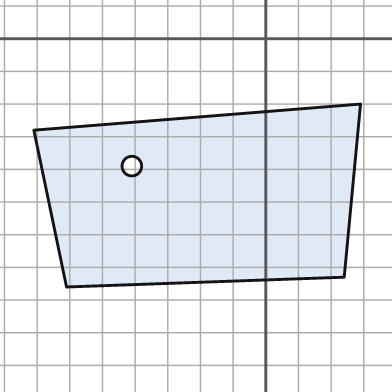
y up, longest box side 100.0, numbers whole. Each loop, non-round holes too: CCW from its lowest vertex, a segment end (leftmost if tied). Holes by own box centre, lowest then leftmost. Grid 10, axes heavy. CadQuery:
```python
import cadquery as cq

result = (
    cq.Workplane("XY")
    .moveTo(-61.0, -76.0)
    .lineTo(24.0, -73.0)
    .lineTo(29.0, -20.0)
    .lineTo(-71.0, -28.0)
    .close()
    .moveTo(-41.0, -39.0)
    .circle(3.0)
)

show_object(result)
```